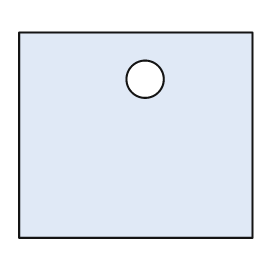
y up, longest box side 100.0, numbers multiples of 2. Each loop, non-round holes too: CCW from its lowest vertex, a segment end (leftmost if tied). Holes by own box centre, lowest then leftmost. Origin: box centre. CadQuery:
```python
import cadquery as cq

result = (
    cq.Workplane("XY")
    .moveTo(-50.0, -44.0)
    .lineTo(50.0, -44.0)
    .lineTo(50.0, 44.0)
    .lineTo(-50.0, 44.0)
    .close()
    .moveTo(4.0, 24.0)
    .circle(8.0)
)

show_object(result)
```